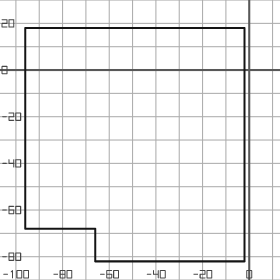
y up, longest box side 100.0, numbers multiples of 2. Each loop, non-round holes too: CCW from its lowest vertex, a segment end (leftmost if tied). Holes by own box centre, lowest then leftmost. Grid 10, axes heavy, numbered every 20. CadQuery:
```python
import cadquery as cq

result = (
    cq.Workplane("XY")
    .moveTo(-66.0, -82.0)
    .lineTo(-2.0, -82.0)
    .lineTo(-2.0, 18.0)
    .lineTo(-96.0, 18.0)
    .lineTo(-96.0, -68.0)
    .lineTo(-66.0, -68.0)
    .close()
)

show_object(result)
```